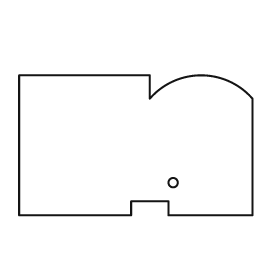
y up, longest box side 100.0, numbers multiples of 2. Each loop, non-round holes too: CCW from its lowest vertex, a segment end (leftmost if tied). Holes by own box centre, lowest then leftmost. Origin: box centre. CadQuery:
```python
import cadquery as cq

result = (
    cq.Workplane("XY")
    .moveTo(-50.0, -30.0)
    .lineTo(-2.0, -30.0)
    .lineTo(-2.0, -24.0)
    .lineTo(14.0, -24.0)
    .lineTo(14.0, -30.0)
    .lineTo(50.0, -30.0)
    .lineTo(50.0, 20.0)
    .threePointArc((28.0, 30.0), (6.0, 20.0))
    .lineTo(6.0, 30.0)
    .lineTo(-50.0, 30.0)
    .close()
    .moveTo(16.0, -16.0)
    .circle(2.0)
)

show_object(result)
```